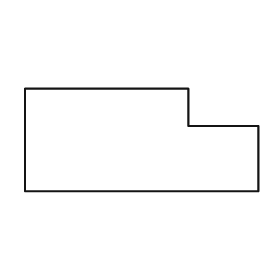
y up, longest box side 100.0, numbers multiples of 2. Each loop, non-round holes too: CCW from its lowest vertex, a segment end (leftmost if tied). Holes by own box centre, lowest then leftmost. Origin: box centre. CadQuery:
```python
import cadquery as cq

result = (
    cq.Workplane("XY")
    .moveTo(-50.0, -22.0)
    .lineTo(50.0, -22.0)
    .lineTo(50.0, 6.0)
    .lineTo(20.0, 6.0)
    .lineTo(20.0, 22.0)
    .lineTo(-50.0, 22.0)
    .close()
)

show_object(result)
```